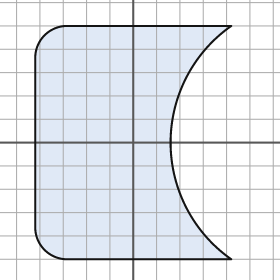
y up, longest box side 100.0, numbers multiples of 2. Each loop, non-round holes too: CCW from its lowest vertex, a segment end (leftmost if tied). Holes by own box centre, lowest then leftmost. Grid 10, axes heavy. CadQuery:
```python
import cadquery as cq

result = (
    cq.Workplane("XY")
    .moveTo(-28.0, -50.0)
    .lineTo(42.0, -50.0)
    .threePointArc((16.0, 0.0), (42.0, 50.0))
    .lineTo(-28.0, 50.0)
    .threePointArc((-38.0, 46.0), (-42.0, 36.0))
    .lineTo(-42.0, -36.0)
    .threePointArc((-38.0, -46.0), (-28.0, -50.0))
    .close()
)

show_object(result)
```